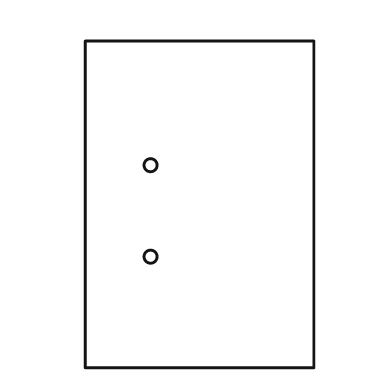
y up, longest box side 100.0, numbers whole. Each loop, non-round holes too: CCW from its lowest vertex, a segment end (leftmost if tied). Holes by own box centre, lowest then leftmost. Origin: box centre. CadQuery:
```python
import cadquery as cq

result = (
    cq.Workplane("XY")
    .moveTo(-35.0, -50.0)
    .lineTo(35.0, -50.0)
    .lineTo(35.0, 50.0)
    .lineTo(-35.0, 50.0)
    .close()
    .moveTo(-15.0, -16.0)
    .circle(2.0)
    .moveTo(-15.0, 12.0)
    .circle(2.0)
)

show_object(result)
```